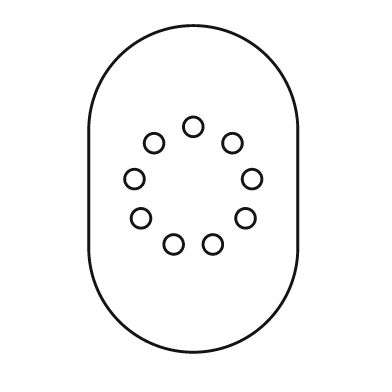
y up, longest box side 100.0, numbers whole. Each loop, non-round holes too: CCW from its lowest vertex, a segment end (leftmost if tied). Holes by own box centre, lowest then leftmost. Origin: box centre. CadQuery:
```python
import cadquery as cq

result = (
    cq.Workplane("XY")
    .moveTo(-32.0, -18.0)
    .threePointArc((0.0, -50.0), (32.0, -18.0))
    .lineTo(32.0, 18.0)
    .threePointArc((0.0, 50.0), (-32.0, 18.0))
    .close()
    .moveTo(-6.0, -17.0)
    .circle(3.0)
    .moveTo(6.0, -17.0)
    .circle(3.0)
    .moveTo(-16.0, -9.0)
    .circle(3.0)
    .moveTo(16.0, -9.0)
    .circle(3.0)
    .moveTo(-18.0, 3.0)
    .circle(3.0)
    .moveTo(18.0, 3.0)
    .circle(3.0)
    .moveTo(-12.0, 14.0)
    .circle(3.0)
    .moveTo(12.0, 14.0)
    .circle(3.0)
    .moveTo(0.0, 19.0)
    .circle(3.0)
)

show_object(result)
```